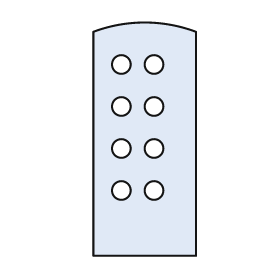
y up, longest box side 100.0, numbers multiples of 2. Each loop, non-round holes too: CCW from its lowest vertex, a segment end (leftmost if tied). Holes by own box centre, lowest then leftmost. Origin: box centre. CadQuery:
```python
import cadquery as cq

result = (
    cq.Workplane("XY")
    .moveTo(-22.0, -50.0)
    .lineTo(22.0, -50.0)
    .lineTo(22.0, 46.0)
    .threePointArc((0.0, 50.0), (-22.0, 46.0))
    .close()
    .moveTo(-10.0, -22.0)
    .circle(4.0)
    .moveTo(4.0, -22.0)
    .circle(4.0)
    .moveTo(-10.0, -4.0)
    .circle(4.0)
    .moveTo(4.0, -4.0)
    .circle(4.0)
    .moveTo(-10.0, 14.0)
    .circle(4.0)
    .moveTo(4.0, 14.0)
    .circle(4.0)
    .moveTo(-10.0, 32.0)
    .circle(4.0)
    .moveTo(4.0, 32.0)
    .circle(4.0)
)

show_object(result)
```